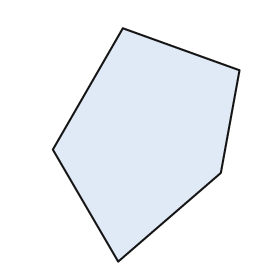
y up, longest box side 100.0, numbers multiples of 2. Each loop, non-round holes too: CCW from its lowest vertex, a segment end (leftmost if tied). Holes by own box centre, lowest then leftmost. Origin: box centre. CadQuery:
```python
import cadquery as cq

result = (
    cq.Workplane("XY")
    .moveTo(-12.0, -50.0)
    .lineTo(32.0, -12.0)
    .lineTo(40.0, 32.0)
    .lineTo(-10.0, 50.0)
    .lineTo(-40.0, -2.0)
    .close()
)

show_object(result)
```